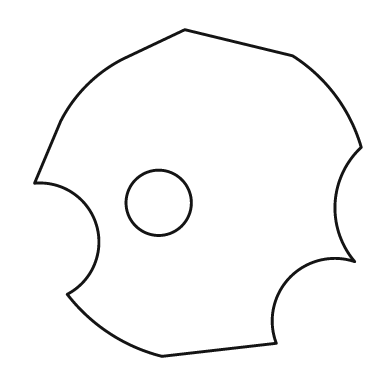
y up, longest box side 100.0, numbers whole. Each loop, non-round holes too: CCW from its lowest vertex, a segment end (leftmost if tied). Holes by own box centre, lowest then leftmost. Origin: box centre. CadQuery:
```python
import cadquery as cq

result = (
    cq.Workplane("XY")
    .moveTo(-11.0, -50.0)
    .lineTo(24.0, -46.0)
    .threePointArc((28.0, -26.0), (48.0, -21.0))
    .threePointArc((42.0, -3.0), (50.0, 14.0))
    .threePointArc((42.0, 30.0), (29.0, 42.0))
    .lineTo(-4.0, 50.0)
    .lineTo(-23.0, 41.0)
    .threePointArc((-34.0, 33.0), (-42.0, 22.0))
    .lineTo(-50.0, 3.0)
    .threePointArc((-31.0, -10.0), (-40.0, -31.0))
    .threePointArc((-27.0, -43.0), (-11.0, -50.0))
    .close()
    .moveTo(-12.0, -3.0)
    .circle(10.0)
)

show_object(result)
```